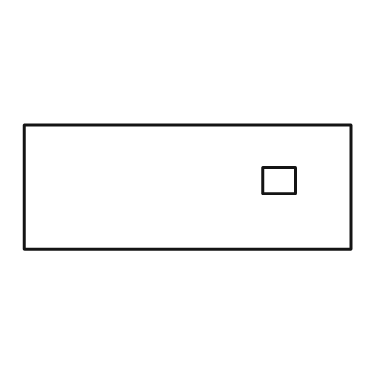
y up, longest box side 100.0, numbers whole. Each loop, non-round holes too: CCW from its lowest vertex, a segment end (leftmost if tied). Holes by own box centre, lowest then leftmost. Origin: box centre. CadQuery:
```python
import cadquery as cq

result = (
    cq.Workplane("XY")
    .moveTo(-50.0, -19.0)
    .lineTo(50.0, -19.0)
    .lineTo(50.0, 19.0)
    .lineTo(-50.0, 19.0)
    .close()
    .moveTo(23.0, -2.0)
    .lineTo(33.0, -2.0)
    .lineTo(33.0, 6.0)
    .lineTo(23.0, 6.0)
    .close()
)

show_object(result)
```